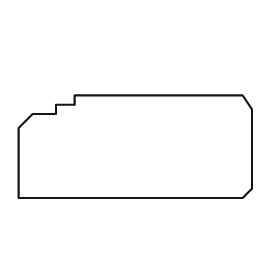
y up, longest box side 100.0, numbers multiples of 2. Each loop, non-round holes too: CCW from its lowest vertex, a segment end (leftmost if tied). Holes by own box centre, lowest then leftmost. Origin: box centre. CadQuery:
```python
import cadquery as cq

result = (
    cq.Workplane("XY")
    .moveTo(-50.0, -22.0)
    .lineTo(46.0, -22.0)
    .lineTo(50.0, -18.0)
    .lineTo(50.0, 16.0)
    .lineTo(46.0, 22.0)
    .lineTo(-26.0, 22.0)
    .lineTo(-26.0, 18.0)
    .lineTo(-34.0, 18.0)
    .lineTo(-34.0, 14.0)
    .lineTo(-44.0, 14.0)
    .lineTo(-50.0, 8.0)
    .close()
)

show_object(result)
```